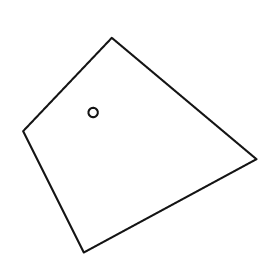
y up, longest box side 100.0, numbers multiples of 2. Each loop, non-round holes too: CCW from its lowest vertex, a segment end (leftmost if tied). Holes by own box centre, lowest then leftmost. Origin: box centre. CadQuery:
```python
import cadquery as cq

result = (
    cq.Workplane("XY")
    .moveTo(-24.0, -46.0)
    .lineTo(50.0, -6.0)
    .lineTo(-12.0, 46.0)
    .lineTo(-50.0, 6.0)
    .close()
    .moveTo(-20.0, 14.0)
    .circle(2.0)
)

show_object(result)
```